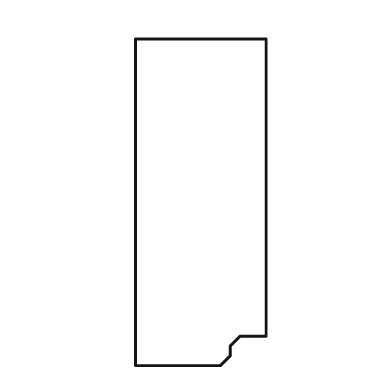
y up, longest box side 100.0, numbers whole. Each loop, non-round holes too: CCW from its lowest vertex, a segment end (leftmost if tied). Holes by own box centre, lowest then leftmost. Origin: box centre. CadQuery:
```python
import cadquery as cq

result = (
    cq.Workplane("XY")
    .moveTo(-20.0, -50.0)
    .lineTo(6.0, -50.0)
    .lineTo(9.0, -47.0)
    .lineTo(9.0, -44.0)
    .lineTo(12.0, -41.0)
    .lineTo(20.0, -41.0)
    .lineTo(20.0, 50.0)
    .lineTo(-20.0, 50.0)
    .close()
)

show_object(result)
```